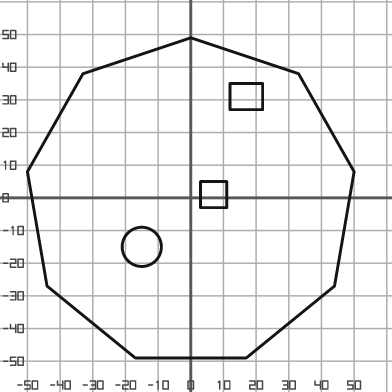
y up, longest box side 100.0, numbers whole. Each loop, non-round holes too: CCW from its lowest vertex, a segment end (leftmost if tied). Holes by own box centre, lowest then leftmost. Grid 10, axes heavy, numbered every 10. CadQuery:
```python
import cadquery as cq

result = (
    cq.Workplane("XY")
    .moveTo(-17.0, -49.0)
    .lineTo(17.0, -49.0)
    .lineTo(44.0, -27.0)
    .lineTo(50.0, 8.0)
    .lineTo(33.0, 38.0)
    .lineTo(0.0, 49.0)
    .lineTo(-33.0, 38.0)
    .lineTo(-50.0, 8.0)
    .lineTo(-44.0, -27.0)
    .close()
    .moveTo(-15.0, -15.0)
    .circle(6.0)
    .moveTo(3.0, -3.0)
    .lineTo(11.0, -3.0)
    .lineTo(11.0, 5.0)
    .lineTo(3.0, 5.0)
    .close()
    .moveTo(12.0, 27.0)
    .lineTo(22.0, 27.0)
    .lineTo(22.0, 35.0)
    .lineTo(12.0, 35.0)
    .close()
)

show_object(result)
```